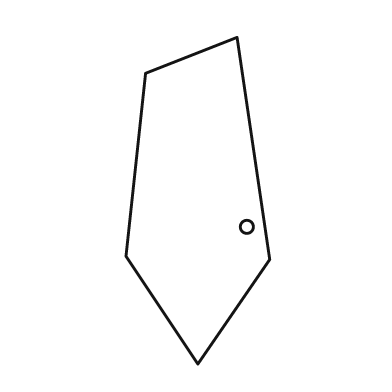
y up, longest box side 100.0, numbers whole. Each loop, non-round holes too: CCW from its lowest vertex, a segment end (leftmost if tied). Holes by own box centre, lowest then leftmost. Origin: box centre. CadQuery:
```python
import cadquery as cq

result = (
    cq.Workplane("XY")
    .moveTo(0.0, -50.0)
    .lineTo(22.0, -18.0)
    .lineTo(12.0, 50.0)
    .lineTo(-16.0, 39.0)
    .lineTo(-22.0, -17.0)
    .close()
    .moveTo(15.0, -8.0)
    .circle(2.0)
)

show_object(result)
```